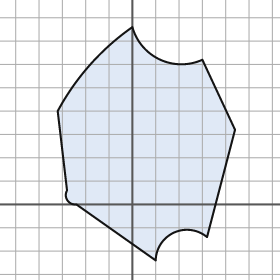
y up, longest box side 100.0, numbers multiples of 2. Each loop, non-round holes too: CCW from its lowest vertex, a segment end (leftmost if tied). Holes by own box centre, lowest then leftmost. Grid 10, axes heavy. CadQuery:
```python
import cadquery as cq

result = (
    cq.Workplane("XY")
    .moveTo(10.0, -24.0)
    .threePointArc((18.0, -12.0), (32.0, -14.0))
    .lineTo(44.0, 32.0)
    .lineTo(30.0, 62.0)
    .threePointArc((12.0, 62.0), (0.0, 76.0))
    .threePointArc((-18.0, 60.0), (-32.0, 40.0))
    .lineTo(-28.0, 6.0)
    .threePointArc((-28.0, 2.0), (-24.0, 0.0))
    .close()
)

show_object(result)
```